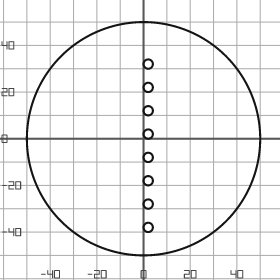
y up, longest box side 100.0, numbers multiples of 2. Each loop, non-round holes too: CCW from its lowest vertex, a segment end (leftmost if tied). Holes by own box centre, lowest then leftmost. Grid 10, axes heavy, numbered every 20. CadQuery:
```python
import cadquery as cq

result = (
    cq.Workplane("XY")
    .moveTo(0.0, 0.0)
    .circle(50.0)
    .moveTo(2.0, -38.0)
    .circle(2.0)
    .moveTo(2.0, -28.0)
    .circle(2.0)
    .moveTo(2.0, -18.0)
    .circle(2.0)
    .moveTo(2.0, -8.0)
    .circle(2.0)
    .moveTo(2.0, 2.0)
    .circle(2.0)
    .moveTo(2.0, 12.0)
    .circle(2.0)
    .moveTo(2.0, 22.0)
    .circle(2.0)
    .moveTo(2.0, 32.0)
    .circle(2.0)
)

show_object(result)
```